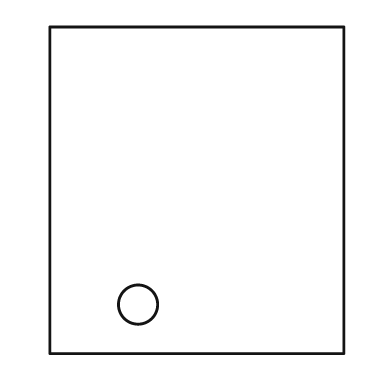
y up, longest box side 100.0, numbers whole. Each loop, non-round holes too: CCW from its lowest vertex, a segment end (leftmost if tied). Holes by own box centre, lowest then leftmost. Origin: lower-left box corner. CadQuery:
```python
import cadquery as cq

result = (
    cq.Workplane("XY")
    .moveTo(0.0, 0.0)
    .lineTo(90.0, 0.0)
    .lineTo(90.0, 100.0)
    .lineTo(0.0, 100.0)
    .close()
    .moveTo(27.0, 15.0)
    .circle(6.0)
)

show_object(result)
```